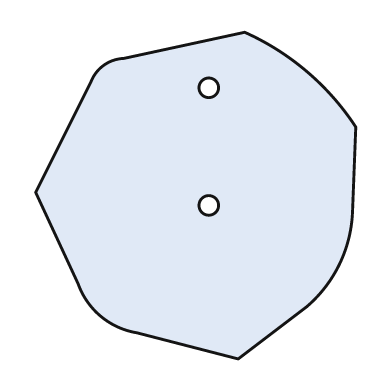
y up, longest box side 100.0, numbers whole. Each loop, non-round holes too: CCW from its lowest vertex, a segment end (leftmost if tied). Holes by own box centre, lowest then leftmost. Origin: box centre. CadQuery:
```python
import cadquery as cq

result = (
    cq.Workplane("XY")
    .moveTo(13.0, -50.0)
    .lineTo(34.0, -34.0)
    .threePointArc((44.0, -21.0), (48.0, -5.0))
    .lineTo(49.0, 21.0)
    .threePointArc((34.0, 38.0), (15.0, 50.0))
    .lineTo(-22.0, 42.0)
    .threePointArc((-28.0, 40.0), (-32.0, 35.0))
    .lineTo(-49.0, 1.0)
    .lineTo(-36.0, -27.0)
    .threePointArc((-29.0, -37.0), (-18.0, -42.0))
    .close()
    .moveTo(4.0, -3.0)
    .circle(3.0)
    .moveTo(4.0, 33.0)
    .circle(3.0)
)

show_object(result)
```